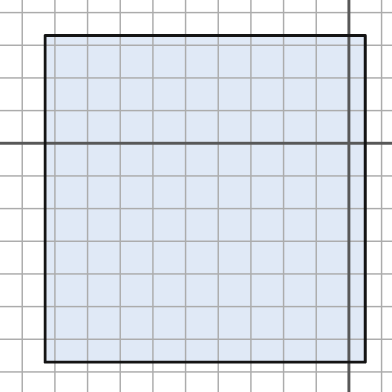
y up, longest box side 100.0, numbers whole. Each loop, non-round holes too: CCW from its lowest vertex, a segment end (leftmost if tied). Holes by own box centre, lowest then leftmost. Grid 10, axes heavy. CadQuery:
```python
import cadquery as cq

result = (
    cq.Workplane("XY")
    .moveTo(-93.0, -67.0)
    .lineTo(5.0, -67.0)
    .lineTo(5.0, 33.0)
    .lineTo(-93.0, 33.0)
    .close()
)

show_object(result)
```